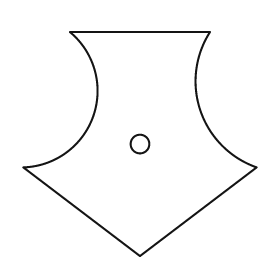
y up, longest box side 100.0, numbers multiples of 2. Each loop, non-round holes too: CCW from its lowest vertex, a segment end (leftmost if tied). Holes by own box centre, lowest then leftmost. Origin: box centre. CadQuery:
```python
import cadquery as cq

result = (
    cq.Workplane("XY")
    .moveTo(0.0, -48.0)
    .lineTo(50.0, -10.0)
    .threePointArc((26.0, 14.0), (30.0, 48.0))
    .lineTo(-30.0, 48.0)
    .threePointArc((-20.0, 12.0), (-50.0, -10.0))
    .close()
    .moveTo(0.0, 0.0)
    .circle(4.0)
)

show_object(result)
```